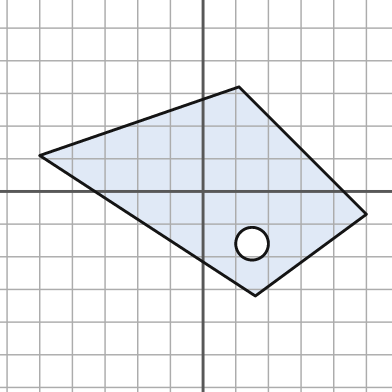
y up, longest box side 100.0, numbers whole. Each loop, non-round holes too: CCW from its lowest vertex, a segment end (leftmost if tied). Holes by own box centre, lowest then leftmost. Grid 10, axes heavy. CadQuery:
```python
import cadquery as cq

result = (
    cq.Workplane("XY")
    .moveTo(16.0, -32.0)
    .lineTo(50.0, -7.0)
    .lineTo(11.0, 32.0)
    .lineTo(-50.0, 11.0)
    .close()
    .moveTo(15.0, -16.0)
    .circle(5.0)
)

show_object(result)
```